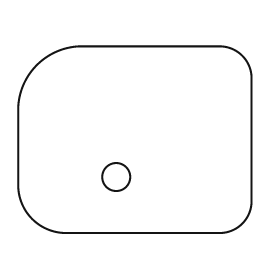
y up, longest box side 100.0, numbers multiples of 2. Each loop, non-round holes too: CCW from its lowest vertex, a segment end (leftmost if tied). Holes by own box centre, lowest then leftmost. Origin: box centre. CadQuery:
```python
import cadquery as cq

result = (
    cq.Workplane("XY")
    .moveTo(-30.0, -40.0)
    .lineTo(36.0, -40.0)
    .threePointArc((46.0, -36.0), (50.0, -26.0))
    .lineTo(50.0, 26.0)
    .threePointArc((46.0, 36.0), (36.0, 40.0))
    .lineTo(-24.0, 40.0)
    .threePointArc((-42.0, 32.0), (-50.0, 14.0))
    .lineTo(-50.0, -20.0)
    .threePointArc((-44.0, -34.0), (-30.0, -40.0))
    .close()
    .moveTo(-8.0, -16.0)
    .circle(6.0)
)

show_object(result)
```